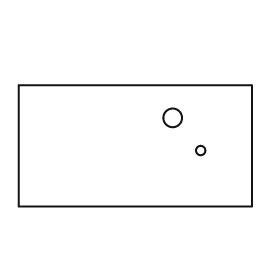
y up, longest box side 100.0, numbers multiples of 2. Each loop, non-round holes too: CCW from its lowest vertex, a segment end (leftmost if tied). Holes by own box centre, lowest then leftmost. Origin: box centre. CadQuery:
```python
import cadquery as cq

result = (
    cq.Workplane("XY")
    .moveTo(-50.0, -26.0)
    .lineTo(50.0, -26.0)
    .lineTo(50.0, 26.0)
    .lineTo(-50.0, 26.0)
    .close()
    .moveTo(28.0, -2.0)
    .circle(2.0)
    .moveTo(16.0, 12.0)
    .circle(4.0)
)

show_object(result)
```